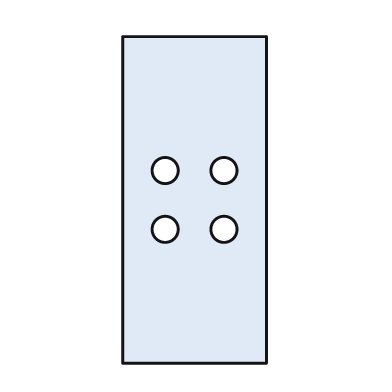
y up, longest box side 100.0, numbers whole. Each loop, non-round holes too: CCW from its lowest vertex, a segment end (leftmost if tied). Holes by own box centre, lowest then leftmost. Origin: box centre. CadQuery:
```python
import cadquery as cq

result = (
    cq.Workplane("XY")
    .moveTo(-22.0, -50.0)
    .lineTo(22.0, -50.0)
    .lineTo(22.0, 50.0)
    .lineTo(-22.0, 50.0)
    .close()
    .moveTo(-9.0, -9.0)
    .circle(4.0)
    .moveTo(9.0, -9.0)
    .circle(4.0)
    .moveTo(-9.0, 9.0)
    .circle(4.0)
    .moveTo(9.0, 9.0)
    .circle(4.0)
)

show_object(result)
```